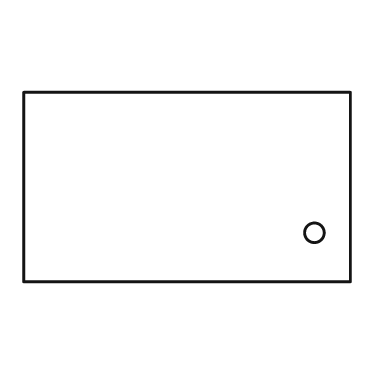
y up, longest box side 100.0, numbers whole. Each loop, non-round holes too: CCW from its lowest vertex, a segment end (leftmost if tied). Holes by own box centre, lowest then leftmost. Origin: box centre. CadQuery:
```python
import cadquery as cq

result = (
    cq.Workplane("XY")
    .moveTo(-50.0, -29.0)
    .lineTo(50.0, -29.0)
    .lineTo(50.0, 29.0)
    .lineTo(-50.0, 29.0)
    .close()
    .moveTo(39.0, -14.0)
    .circle(3.0)
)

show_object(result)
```